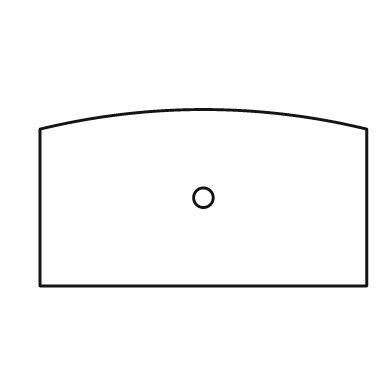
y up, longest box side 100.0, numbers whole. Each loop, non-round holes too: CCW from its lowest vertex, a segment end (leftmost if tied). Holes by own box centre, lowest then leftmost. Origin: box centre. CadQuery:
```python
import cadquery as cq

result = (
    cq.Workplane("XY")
    .moveTo(-50.0, -27.0)
    .lineTo(50.0, -27.0)
    .lineTo(50.0, 21.0)
    .threePointArc((0.0, 27.0), (-50.0, 21.0))
    .close()
    .moveTo(0.0, 0.0)
    .circle(3.0)
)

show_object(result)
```